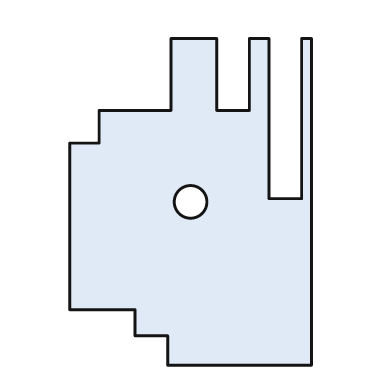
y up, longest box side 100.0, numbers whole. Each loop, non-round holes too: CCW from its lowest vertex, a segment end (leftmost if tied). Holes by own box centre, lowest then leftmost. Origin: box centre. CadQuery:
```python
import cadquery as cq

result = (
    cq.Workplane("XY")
    .moveTo(-7.0, -50.0)
    .lineTo(37.0, -50.0)
    .lineTo(37.0, 50.0)
    .lineTo(34.0, 50.0)
    .lineTo(34.0, 1.0)
    .lineTo(24.0, 1.0)
    .lineTo(24.0, 50.0)
    .lineTo(18.0, 50.0)
    .lineTo(18.0, 28.0)
    .lineTo(8.0, 28.0)
    .lineTo(8.0, 50.0)
    .lineTo(-6.0, 50.0)
    .lineTo(-6.0, 28.0)
    .lineTo(-28.0, 28.0)
    .lineTo(-28.0, 18.0)
    .lineTo(-37.0, 18.0)
    .lineTo(-37.0, -33.0)
    .lineTo(-17.0, -33.0)
    .lineTo(-17.0, -41.0)
    .lineTo(-7.0, -41.0)
    .close()
    .moveTo(0.0, 0.0)
    .circle(5.0)
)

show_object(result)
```